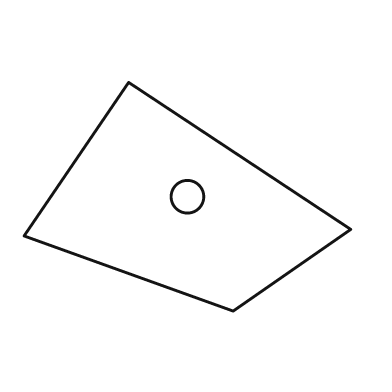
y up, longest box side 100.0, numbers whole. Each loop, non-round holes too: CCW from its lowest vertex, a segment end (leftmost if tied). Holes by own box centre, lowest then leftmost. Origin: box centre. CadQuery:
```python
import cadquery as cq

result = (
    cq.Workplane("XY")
    .moveTo(14.0, -35.0)
    .lineTo(50.0, -10.0)
    .lineTo(-18.0, 35.0)
    .lineTo(-50.0, -12.0)
    .close()
    .moveTo(0.0, 0.0)
    .circle(5.0)
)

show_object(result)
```